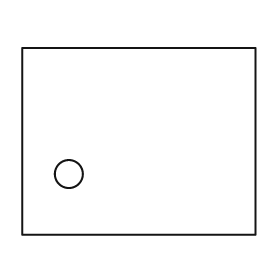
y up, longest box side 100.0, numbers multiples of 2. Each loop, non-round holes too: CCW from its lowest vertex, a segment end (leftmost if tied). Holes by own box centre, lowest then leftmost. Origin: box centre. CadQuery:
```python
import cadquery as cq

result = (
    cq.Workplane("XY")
    .moveTo(-50.0, -40.0)
    .lineTo(50.0, -40.0)
    .lineTo(50.0, 40.0)
    .lineTo(-50.0, 40.0)
    .close()
    .moveTo(-30.0, -14.0)
    .circle(6.0)
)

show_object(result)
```